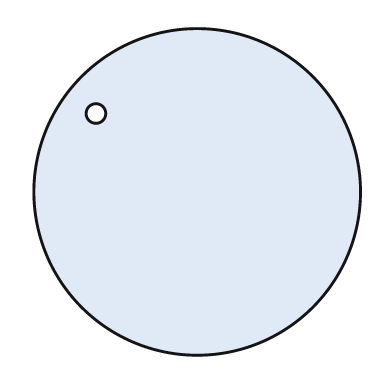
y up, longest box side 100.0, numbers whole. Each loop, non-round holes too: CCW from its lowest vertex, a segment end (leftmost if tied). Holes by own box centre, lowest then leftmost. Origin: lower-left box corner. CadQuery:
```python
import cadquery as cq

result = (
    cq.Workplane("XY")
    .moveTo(50.0, 50.0)
    .circle(50.0)
    .moveTo(19.0, 74.0)
    .circle(3.0)
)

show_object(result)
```